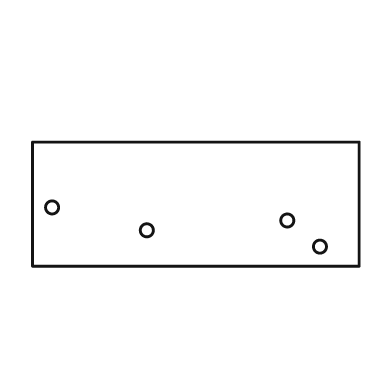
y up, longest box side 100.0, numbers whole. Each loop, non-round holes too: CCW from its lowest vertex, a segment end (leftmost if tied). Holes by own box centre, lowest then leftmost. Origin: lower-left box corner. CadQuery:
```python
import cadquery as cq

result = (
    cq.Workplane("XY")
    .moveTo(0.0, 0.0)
    .lineTo(100.0, 0.0)
    .lineTo(100.0, 38.0)
    .lineTo(0.0, 38.0)
    .close()
    .moveTo(88.0, 6.0)
    .circle(2.0)
    .moveTo(35.0, 11.0)
    .circle(2.0)
    .moveTo(78.0, 14.0)
    .circle(2.0)
    .moveTo(6.0, 18.0)
    .circle(2.0)
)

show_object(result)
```